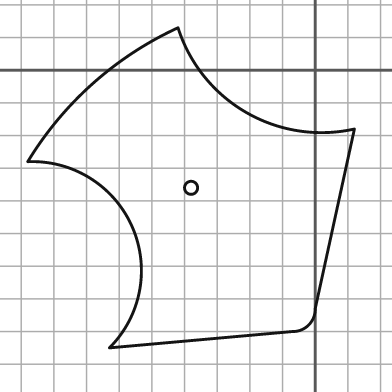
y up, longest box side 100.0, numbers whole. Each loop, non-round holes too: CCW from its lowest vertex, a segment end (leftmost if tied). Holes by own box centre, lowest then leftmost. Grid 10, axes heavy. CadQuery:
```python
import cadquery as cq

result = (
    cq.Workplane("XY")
    .moveTo(-63.0, -85.0)
    .lineTo(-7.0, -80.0)
    .threePointArc((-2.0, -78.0), (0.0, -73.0))
    .lineTo(12.0, -18.0)
    .threePointArc((-21.0, -13.0), (-42.0, 13.0))
    .threePointArc((-68.0, -4.0), (-88.0, -28.0))
    .threePointArc((-56.0, -48.0), (-63.0, -85.0))
    .close()
    .moveTo(-38.0, -36.0)
    .circle(2.0)
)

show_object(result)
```